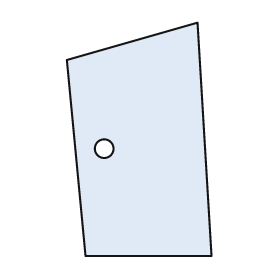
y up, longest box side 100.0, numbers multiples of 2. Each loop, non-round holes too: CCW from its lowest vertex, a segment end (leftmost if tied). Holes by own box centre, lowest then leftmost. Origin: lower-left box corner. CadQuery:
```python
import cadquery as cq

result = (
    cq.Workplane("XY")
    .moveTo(8.0, 0.0)
    .lineTo(62.0, 0.0)
    .lineTo(56.0, 100.0)
    .lineTo(0.0, 84.0)
    .close()
    .moveTo(16.0, 46.0)
    .circle(4.0)
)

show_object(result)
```